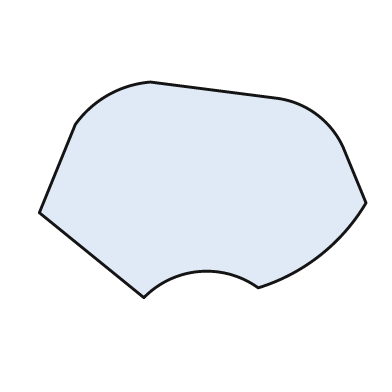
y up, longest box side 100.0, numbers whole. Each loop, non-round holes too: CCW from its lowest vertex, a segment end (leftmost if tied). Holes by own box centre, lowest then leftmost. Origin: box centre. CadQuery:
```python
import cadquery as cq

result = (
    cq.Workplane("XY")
    .moveTo(-18.0, -33.0)
    .threePointArc((-1.0, -25.0), (17.0, -30.0))
    .threePointArc((36.0, -20.0), (50.0, -4.0))
    .lineTo(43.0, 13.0)
    .threePointArc((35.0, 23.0), (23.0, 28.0))
    .lineTo(-16.0, 33.0)
    .threePointArc((-29.0, 29.0), (-39.0, 20.0))
    .lineTo(-50.0, -7.0)
    .close()
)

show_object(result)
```